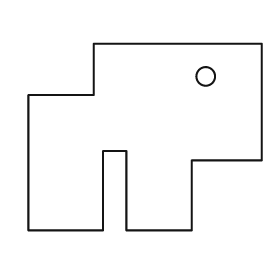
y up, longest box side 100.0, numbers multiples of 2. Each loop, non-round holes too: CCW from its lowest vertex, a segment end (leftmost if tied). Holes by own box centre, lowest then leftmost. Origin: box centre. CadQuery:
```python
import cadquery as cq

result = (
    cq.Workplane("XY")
    .moveTo(-50.0, -40.0)
    .lineTo(-18.0, -40.0)
    .lineTo(-18.0, -6.0)
    .lineTo(-8.0, -6.0)
    .lineTo(-8.0, -40.0)
    .lineTo(20.0, -40.0)
    .lineTo(20.0, -10.0)
    .lineTo(50.0, -10.0)
    .lineTo(50.0, 40.0)
    .lineTo(-22.0, 40.0)
    .lineTo(-22.0, 18.0)
    .lineTo(-50.0, 18.0)
    .close()
    .moveTo(26.0, 26.0)
    .circle(4.0)
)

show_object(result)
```